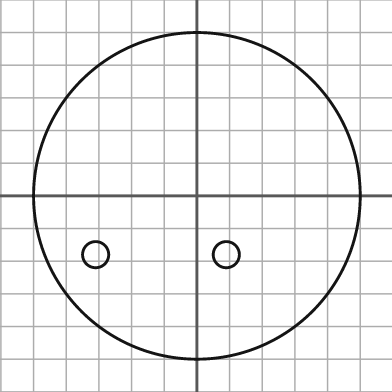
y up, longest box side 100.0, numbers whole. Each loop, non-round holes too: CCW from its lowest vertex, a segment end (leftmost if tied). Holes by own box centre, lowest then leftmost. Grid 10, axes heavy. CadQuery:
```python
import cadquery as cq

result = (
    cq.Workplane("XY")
    .moveTo(0.0, 0.0)
    .circle(50.0)
    .moveTo(-31.0, -18.0)
    .circle(4.0)
    .moveTo(9.0, -18.0)
    .circle(4.0)
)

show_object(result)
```